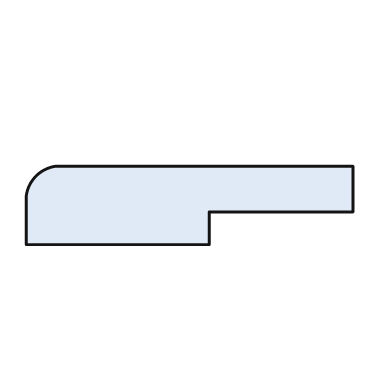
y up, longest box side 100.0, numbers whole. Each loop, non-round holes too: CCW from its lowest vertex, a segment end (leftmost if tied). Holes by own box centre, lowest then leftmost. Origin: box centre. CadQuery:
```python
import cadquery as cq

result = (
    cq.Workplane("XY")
    .moveTo(-50.0, -12.0)
    .lineTo(6.0, -12.0)
    .lineTo(6.0, -2.0)
    .lineTo(50.0, -2.0)
    .lineTo(50.0, 12.0)
    .lineTo(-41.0, 12.0)
    .threePointArc((-47.0, 9.0), (-50.0, 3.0))
    .close()
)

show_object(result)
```